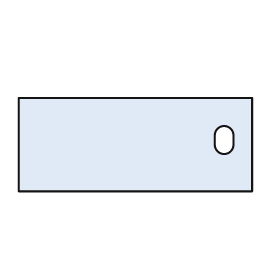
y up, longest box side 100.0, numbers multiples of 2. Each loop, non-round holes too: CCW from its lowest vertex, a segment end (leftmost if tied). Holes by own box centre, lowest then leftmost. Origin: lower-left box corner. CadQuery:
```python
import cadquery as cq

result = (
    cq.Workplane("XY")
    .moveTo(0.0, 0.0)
    .lineTo(100.0, 0.0)
    .lineTo(100.0, 40.0)
    .lineTo(0.0, 40.0)
    .close()
    .moveTo(84.0, 20.0)
    .threePointArc((88.0, 16.0), (92.0, 20.0))
    .lineTo(92.0, 24.0)
    .threePointArc((88.0, 28.0), (84.0, 24.0))
    .close()
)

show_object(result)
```